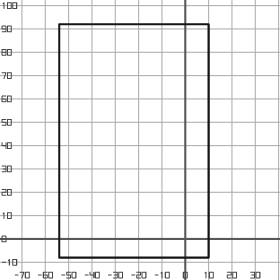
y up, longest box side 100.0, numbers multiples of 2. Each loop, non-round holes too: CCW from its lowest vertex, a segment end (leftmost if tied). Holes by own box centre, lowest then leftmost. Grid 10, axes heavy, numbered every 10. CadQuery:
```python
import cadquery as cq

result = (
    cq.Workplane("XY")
    .moveTo(-54.0, -8.0)
    .lineTo(10.0, -8.0)
    .lineTo(10.0, 92.0)
    .lineTo(-54.0, 92.0)
    .close()
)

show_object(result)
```